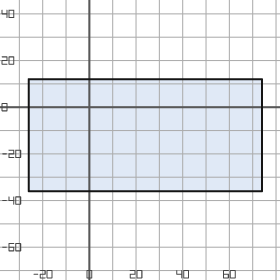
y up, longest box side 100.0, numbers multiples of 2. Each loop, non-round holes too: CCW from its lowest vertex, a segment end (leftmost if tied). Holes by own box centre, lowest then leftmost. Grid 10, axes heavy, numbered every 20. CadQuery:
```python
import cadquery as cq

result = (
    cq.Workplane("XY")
    .moveTo(-26.0, -36.0)
    .lineTo(74.0, -36.0)
    .lineTo(74.0, 12.0)
    .lineTo(-26.0, 12.0)
    .close()
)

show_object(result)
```